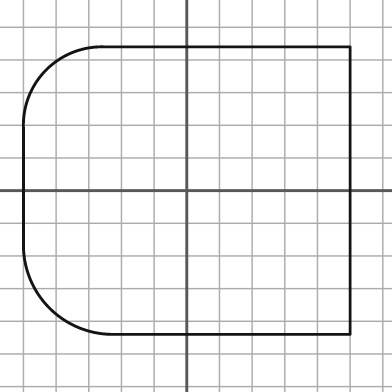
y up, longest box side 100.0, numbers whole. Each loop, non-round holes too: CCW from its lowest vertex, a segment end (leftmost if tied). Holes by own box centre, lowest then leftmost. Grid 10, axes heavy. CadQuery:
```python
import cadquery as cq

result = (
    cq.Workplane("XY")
    .moveTo(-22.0, -44.0)
    .lineTo(50.0, -44.0)
    .lineTo(50.0, 44.0)
    .lineTo(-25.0, 44.0)
    .threePointArc((-43.0, 37.0), (-50.0, 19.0))
    .lineTo(-50.0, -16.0)
    .threePointArc((-42.0, -36.0), (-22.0, -44.0))
    .close()
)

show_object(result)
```